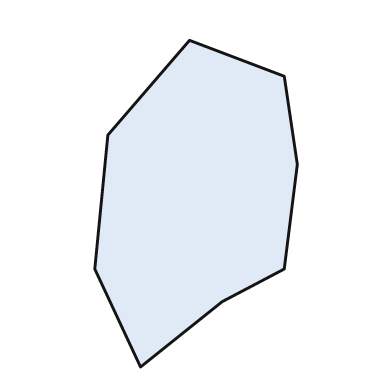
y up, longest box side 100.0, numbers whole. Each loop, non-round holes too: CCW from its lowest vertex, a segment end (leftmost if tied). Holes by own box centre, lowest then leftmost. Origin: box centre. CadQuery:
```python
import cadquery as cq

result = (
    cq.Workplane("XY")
    .moveTo(-17.0, -50.0)
    .lineTo(8.0, -30.0)
    .lineTo(27.0, -20.0)
    .lineTo(31.0, 12.0)
    .lineTo(27.0, 39.0)
    .lineTo(-2.0, 50.0)
    .lineTo(-27.0, 21.0)
    .lineTo(-31.0, -20.0)
    .close()
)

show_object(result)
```